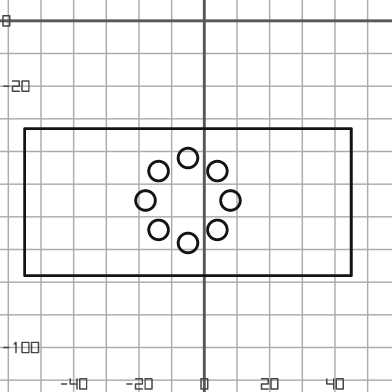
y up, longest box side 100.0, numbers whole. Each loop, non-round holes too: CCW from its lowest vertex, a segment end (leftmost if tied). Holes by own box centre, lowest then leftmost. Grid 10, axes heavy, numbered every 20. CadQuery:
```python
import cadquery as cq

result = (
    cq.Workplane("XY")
    .moveTo(-55.0, -78.0)
    .lineTo(45.0, -78.0)
    .lineTo(45.0, -33.0)
    .lineTo(-55.0, -33.0)
    .close()
    .moveTo(-5.0, -68.0)
    .circle(3.0)
    .moveTo(-14.0, -64.0)
    .circle(3.0)
    .moveTo(4.0, -64.0)
    .circle(3.0)
    .moveTo(-18.0, -55.0)
    .circle(3.0)
    .moveTo(8.0, -55.0)
    .circle(3.0)
    .moveTo(-14.0, -46.0)
    .circle(3.0)
    .moveTo(4.0, -46.0)
    .circle(3.0)
    .moveTo(-5.0, -42.0)
    .circle(3.0)
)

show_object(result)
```